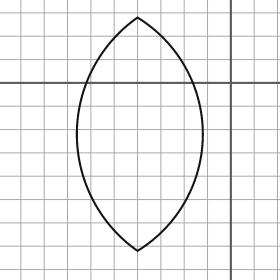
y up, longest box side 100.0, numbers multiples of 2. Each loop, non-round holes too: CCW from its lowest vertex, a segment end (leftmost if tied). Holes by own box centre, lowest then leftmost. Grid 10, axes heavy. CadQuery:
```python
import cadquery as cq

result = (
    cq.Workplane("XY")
    .moveTo(-40.0, -72.0)
    .threePointArc((-12.0, -22.0), (-40.0, 28.0))
    .threePointArc((-66.0, -22.0), (-40.0, -72.0))
    .close()
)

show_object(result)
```